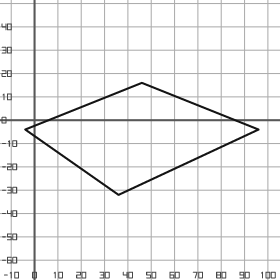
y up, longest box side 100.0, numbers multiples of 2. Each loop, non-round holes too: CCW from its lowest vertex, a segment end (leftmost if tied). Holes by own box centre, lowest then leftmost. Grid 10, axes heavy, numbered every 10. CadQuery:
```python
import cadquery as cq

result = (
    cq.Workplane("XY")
    .moveTo(36.0, -32.0)
    .lineTo(96.0, -4.0)
    .lineTo(46.0, 16.0)
    .lineTo(-4.0, -4.0)
    .close()
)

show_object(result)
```